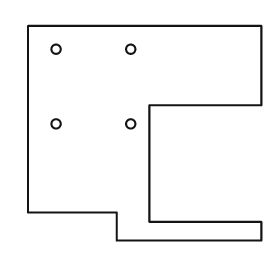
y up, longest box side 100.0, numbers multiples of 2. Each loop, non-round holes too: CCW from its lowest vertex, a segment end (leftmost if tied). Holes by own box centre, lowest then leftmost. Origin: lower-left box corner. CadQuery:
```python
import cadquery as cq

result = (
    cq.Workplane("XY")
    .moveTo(38.0, 0.0)
    .lineTo(100.0, 0.0)
    .lineTo(100.0, 8.0)
    .lineTo(52.0, 8.0)
    .lineTo(52.0, 58.0)
    .lineTo(100.0, 58.0)
    .lineTo(100.0, 92.0)
    .lineTo(0.0, 92.0)
    .lineTo(0.0, 12.0)
    .lineTo(38.0, 12.0)
    .close()
    .moveTo(12.0, 50.0)
    .circle(2.0)
    .moveTo(44.0, 50.0)
    .circle(2.0)
    .moveTo(12.0, 82.0)
    .circle(2.0)
    .moveTo(44.0, 82.0)
    .circle(2.0)
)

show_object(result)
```